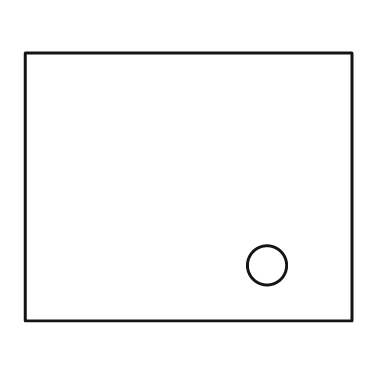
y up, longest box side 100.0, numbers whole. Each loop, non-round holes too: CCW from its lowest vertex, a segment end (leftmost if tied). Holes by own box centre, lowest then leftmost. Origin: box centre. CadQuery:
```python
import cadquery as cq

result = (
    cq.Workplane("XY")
    .moveTo(-50.0, -41.0)
    .lineTo(50.0, -41.0)
    .lineTo(50.0, 41.0)
    .lineTo(-50.0, 41.0)
    .close()
    .moveTo(24.0, -24.0)
    .circle(6.0)
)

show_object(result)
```